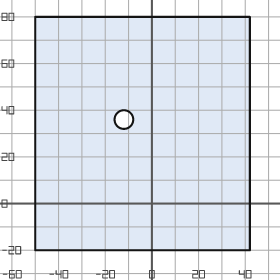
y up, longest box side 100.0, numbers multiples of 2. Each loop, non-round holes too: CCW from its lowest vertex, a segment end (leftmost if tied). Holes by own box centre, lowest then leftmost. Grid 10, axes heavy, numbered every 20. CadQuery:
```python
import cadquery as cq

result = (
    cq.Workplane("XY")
    .moveTo(-50.0, -20.0)
    .lineTo(42.0, -20.0)
    .lineTo(42.0, 80.0)
    .lineTo(-50.0, 80.0)
    .close()
    .moveTo(-12.0, 36.0)
    .circle(4.0)
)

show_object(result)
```